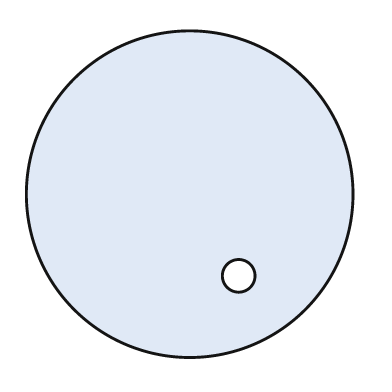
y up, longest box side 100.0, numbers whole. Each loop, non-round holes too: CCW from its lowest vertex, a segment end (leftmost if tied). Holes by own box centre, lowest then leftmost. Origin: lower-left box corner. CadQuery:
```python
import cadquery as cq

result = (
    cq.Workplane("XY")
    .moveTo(50.0, 50.0)
    .circle(50.0)
    .moveTo(65.0, 25.0)
    .circle(5.0)
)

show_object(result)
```